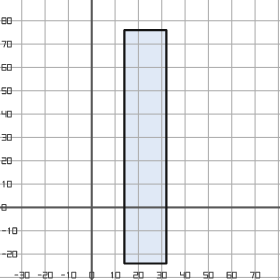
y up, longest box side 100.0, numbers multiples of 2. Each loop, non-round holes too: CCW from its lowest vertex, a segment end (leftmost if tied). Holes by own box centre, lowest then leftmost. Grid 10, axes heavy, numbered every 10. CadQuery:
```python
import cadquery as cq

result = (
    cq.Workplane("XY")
    .moveTo(14.0, -24.0)
    .lineTo(32.0, -24.0)
    .lineTo(32.0, 76.0)
    .lineTo(14.0, 76.0)
    .close()
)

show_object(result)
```